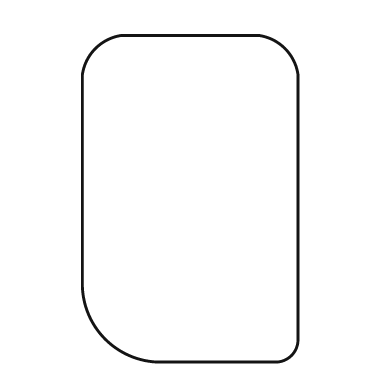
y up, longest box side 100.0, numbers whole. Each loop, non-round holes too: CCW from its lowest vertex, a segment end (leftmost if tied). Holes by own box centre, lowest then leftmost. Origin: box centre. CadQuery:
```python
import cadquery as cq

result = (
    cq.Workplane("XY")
    .moveTo(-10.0, -50.0)
    .lineTo(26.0, -50.0)
    .threePointArc((31.0, -48.0), (33.0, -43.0))
    .lineTo(33.0, 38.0)
    .threePointArc((29.0, 46.0), (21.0, 50.0))
    .lineTo(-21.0, 50.0)
    .threePointArc((-29.0, 46.0), (-33.0, 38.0))
    .lineTo(-33.0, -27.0)
    .threePointArc((-26.0, -43.0), (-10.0, -50.0))
    .close()
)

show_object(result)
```